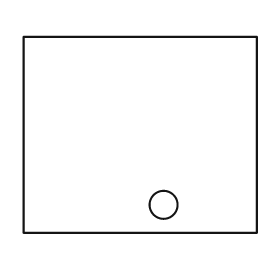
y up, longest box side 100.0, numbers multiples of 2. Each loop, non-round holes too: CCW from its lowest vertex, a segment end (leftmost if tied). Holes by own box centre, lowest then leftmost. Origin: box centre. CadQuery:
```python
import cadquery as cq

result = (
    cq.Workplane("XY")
    .moveTo(-50.0, -42.0)
    .lineTo(50.0, -42.0)
    .lineTo(50.0, 42.0)
    .lineTo(-50.0, 42.0)
    .close()
    .moveTo(10.0, -30.0)
    .circle(6.0)
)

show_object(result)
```